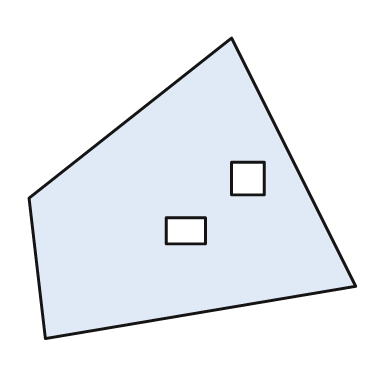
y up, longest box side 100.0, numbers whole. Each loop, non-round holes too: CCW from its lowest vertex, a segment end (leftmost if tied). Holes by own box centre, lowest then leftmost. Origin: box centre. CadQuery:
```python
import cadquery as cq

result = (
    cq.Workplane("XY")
    .moveTo(-45.0, -46.0)
    .lineTo(50.0, -30.0)
    .lineTo(12.0, 46.0)
    .lineTo(-50.0, -3.0)
    .close()
    .moveTo(-8.0, -17.0)
    .lineTo(4.0, -17.0)
    .lineTo(4.0, -9.0)
    .lineTo(-8.0, -9.0)
    .close()
    .moveTo(12.0, -2.0)
    .lineTo(22.0, -2.0)
    .lineTo(22.0, 8.0)
    .lineTo(12.0, 8.0)
    .close()
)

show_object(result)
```